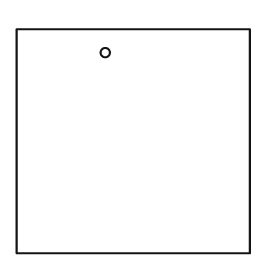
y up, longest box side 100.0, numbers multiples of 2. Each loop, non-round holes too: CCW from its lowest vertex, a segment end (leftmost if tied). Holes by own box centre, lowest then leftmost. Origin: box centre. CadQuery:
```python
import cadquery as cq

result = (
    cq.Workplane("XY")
    .moveTo(-50.0, -48.0)
    .lineTo(50.0, -48.0)
    .lineTo(50.0, 48.0)
    .lineTo(-50.0, 48.0)
    .close()
    .moveTo(-12.0, 38.0)
    .circle(2.0)
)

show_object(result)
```